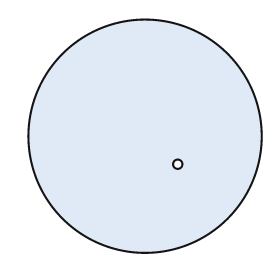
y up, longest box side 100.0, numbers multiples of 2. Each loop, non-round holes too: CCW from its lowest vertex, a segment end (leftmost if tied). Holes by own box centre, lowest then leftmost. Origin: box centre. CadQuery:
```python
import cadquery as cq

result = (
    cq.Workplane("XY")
    .moveTo(0.0, 0.0)
    .circle(50.0)
    .moveTo(14.0, -12.0)
    .circle(2.0)
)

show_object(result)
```